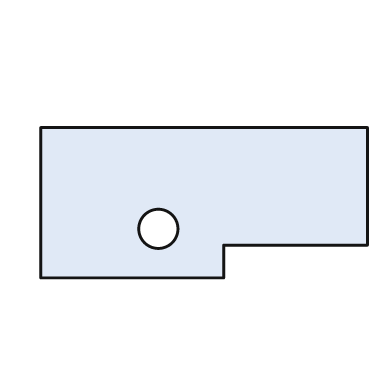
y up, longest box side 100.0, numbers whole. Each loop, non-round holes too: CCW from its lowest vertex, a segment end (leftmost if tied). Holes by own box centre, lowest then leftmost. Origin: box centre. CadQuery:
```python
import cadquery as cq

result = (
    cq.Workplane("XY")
    .moveTo(-50.0, -23.0)
    .lineTo(6.0, -23.0)
    .lineTo(6.0, -13.0)
    .lineTo(50.0, -13.0)
    .lineTo(50.0, 23.0)
    .lineTo(-50.0, 23.0)
    .close()
    .moveTo(-14.0, -8.0)
    .circle(6.0)
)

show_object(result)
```